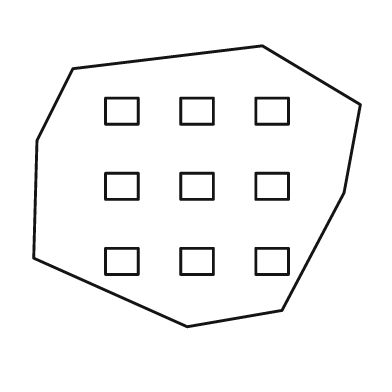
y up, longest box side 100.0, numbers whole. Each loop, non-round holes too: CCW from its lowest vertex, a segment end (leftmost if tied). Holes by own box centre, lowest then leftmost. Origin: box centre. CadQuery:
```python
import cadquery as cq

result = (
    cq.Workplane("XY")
    .moveTo(-3.0, -43.0)
    .lineTo(26.0, -38.0)
    .lineTo(45.0, -2.0)
    .lineTo(50.0, 25.0)
    .lineTo(20.0, 43.0)
    .lineTo(-38.0, 36.0)
    .lineTo(-49.0, 14.0)
    .lineTo(-50.0, -22.0)
    .close()
    .moveTo(-28.0, -27.0)
    .lineTo(-18.0, -27.0)
    .lineTo(-18.0, -19.0)
    .lineTo(-28.0, -19.0)
    .close()
    .moveTo(-5.0, -27.0)
    .lineTo(5.0, -27.0)
    .lineTo(5.0, -19.0)
    .lineTo(-5.0, -19.0)
    .close()
    .moveTo(18.0, -27.0)
    .lineTo(28.0, -27.0)
    .lineTo(28.0, -19.0)
    .lineTo(18.0, -19.0)
    .close()
    .moveTo(-28.0, -4.0)
    .lineTo(-18.0, -4.0)
    .lineTo(-18.0, 4.0)
    .lineTo(-28.0, 4.0)
    .close()
    .moveTo(-5.0, -4.0)
    .lineTo(5.0, -4.0)
    .lineTo(5.0, 4.0)
    .lineTo(-5.0, 4.0)
    .close()
    .moveTo(18.0, -4.0)
    .lineTo(28.0, -4.0)
    .lineTo(28.0, 4.0)
    .lineTo(18.0, 4.0)
    .close()
    .moveTo(-28.0, 19.0)
    .lineTo(-18.0, 19.0)
    .lineTo(-18.0, 27.0)
    .lineTo(-28.0, 27.0)
    .close()
    .moveTo(-5.0, 19.0)
    .lineTo(5.0, 19.0)
    .lineTo(5.0, 27.0)
    .lineTo(-5.0, 27.0)
    .close()
    .moveTo(18.0, 19.0)
    .lineTo(28.0, 19.0)
    .lineTo(28.0, 27.0)
    .lineTo(18.0, 27.0)
    .close()
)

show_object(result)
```